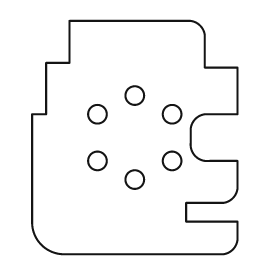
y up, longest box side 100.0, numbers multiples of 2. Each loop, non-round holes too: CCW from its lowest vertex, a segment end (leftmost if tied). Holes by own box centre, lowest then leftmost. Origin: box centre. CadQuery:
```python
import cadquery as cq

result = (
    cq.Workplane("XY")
    .moveTo(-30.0, -50.0)
    .lineTo(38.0, -50.0)
    .threePointArc((42.0, -48.0), (44.0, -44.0))
    .lineTo(44.0, -36.0)
    .lineTo(22.0, -36.0)
    .lineTo(22.0, -28.0)
    .lineTo(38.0, -28.0)
    .threePointArc((42.0, -26.0), (44.0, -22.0))
    .lineTo(44.0, -10.0)
    .lineTo(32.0, -10.0)
    .threePointArc((26.0, -8.0), (24.0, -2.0))
    .lineTo(24.0, 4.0)
    .threePointArc((26.0, 8.0), (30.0, 10.0))
    .lineTo(44.0, 10.0)
    .lineTo(44.0, 30.0)
    .lineTo(30.0, 30.0)
    .lineTo(30.0, 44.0)
    .threePointArc((28.0, 48.0), (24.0, 50.0))
    .lineTo(-28.0, 50.0)
    .lineTo(-28.0, 32.0)
    .lineTo(-38.0, 32.0)
    .lineTo(-38.0, 10.0)
    .lineTo(-44.0, 10.0)
    .lineTo(-44.0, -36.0)
    .threePointArc((-40.0, -46.0), (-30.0, -50.0))
    .close()
    .moveTo(0.0, -18.0)
    .circle(4.0)
    .moveTo(-16.0, -10.0)
    .circle(4.0)
    .moveTo(16.0, -10.0)
    .circle(4.0)
    .moveTo(-16.0, 10.0)
    .circle(4.0)
    .moveTo(16.0, 10.0)
    .circle(4.0)
    .moveTo(0.0, 18.0)
    .circle(4.0)
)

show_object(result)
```